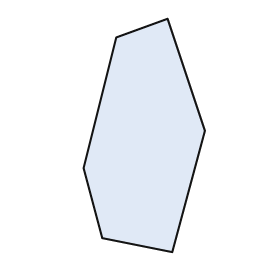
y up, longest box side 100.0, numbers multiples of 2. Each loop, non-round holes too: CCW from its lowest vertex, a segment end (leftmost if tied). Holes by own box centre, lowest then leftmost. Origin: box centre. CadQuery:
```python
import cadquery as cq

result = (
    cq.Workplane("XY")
    .moveTo(12.0, -50.0)
    .lineTo(26.0, 2.0)
    .lineTo(10.0, 50.0)
    .lineTo(-12.0, 42.0)
    .lineTo(-26.0, -14.0)
    .lineTo(-18.0, -44.0)
    .close()
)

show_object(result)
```